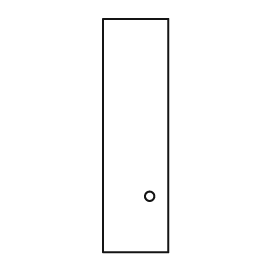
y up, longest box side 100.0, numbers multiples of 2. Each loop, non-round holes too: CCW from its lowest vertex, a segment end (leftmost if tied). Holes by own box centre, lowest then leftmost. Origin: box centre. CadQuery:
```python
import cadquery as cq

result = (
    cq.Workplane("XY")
    .moveTo(-14.0, -50.0)
    .lineTo(14.0, -50.0)
    .lineTo(14.0, 50.0)
    .lineTo(-14.0, 50.0)
    .close()
    .moveTo(6.0, -26.0)
    .circle(2.0)
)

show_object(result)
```